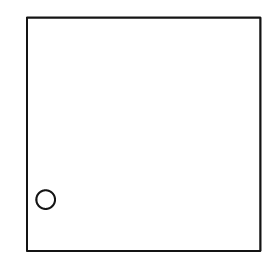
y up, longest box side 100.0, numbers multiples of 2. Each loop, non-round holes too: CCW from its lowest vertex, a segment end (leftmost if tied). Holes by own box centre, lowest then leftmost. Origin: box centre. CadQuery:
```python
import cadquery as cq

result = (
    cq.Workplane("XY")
    .moveTo(-50.0, -50.0)
    .lineTo(50.0, -50.0)
    .lineTo(50.0, 50.0)
    .lineTo(-50.0, 50.0)
    .close()
    .moveTo(-42.0, -28.0)
    .circle(4.0)
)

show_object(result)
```